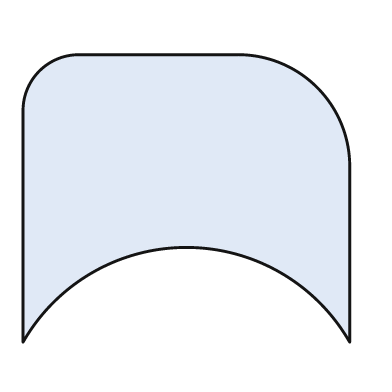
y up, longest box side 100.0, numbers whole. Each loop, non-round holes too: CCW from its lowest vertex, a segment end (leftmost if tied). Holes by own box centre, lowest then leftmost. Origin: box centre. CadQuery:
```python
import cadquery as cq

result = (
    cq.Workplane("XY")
    .moveTo(-50.0, -44.0)
    .threePointArc((0.0, -15.0), (50.0, -44.0))
    .lineTo(50.0, 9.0)
    .threePointArc((40.0, 34.0), (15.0, 44.0))
    .lineTo(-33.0, 44.0)
    .threePointArc((-45.0, 39.0), (-50.0, 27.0))
    .close()
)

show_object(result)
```